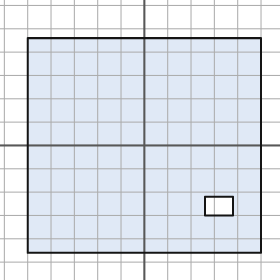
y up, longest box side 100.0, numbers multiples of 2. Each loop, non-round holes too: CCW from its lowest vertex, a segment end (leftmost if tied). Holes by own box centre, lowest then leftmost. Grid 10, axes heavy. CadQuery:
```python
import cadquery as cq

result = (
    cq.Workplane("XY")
    .moveTo(-50.0, -46.0)
    .lineTo(50.0, -46.0)
    .lineTo(50.0, 46.0)
    .lineTo(-50.0, 46.0)
    .close()
    .moveTo(26.0, -30.0)
    .lineTo(38.0, -30.0)
    .lineTo(38.0, -22.0)
    .lineTo(26.0, -22.0)
    .close()
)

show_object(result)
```